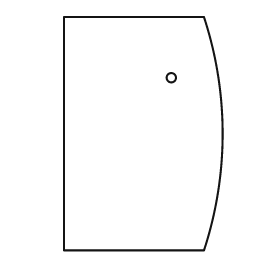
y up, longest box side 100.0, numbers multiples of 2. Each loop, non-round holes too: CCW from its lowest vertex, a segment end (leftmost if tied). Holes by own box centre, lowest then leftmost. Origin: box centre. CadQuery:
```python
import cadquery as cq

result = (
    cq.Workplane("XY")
    .moveTo(-34.0, -50.0)
    .lineTo(26.0, -50.0)
    .threePointArc((34.0, 0.0), (26.0, 50.0))
    .lineTo(-34.0, 50.0)
    .close()
    .moveTo(12.0, 24.0)
    .circle(2.0)
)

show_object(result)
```